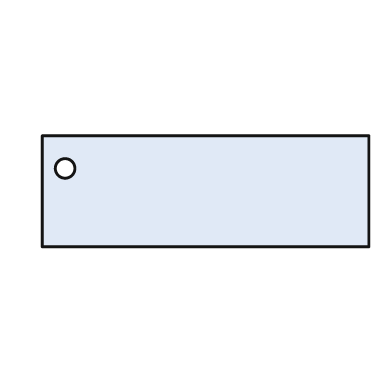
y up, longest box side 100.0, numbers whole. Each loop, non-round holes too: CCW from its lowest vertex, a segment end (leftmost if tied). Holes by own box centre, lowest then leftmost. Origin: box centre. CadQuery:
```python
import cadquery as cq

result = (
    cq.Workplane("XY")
    .moveTo(-50.0, -17.0)
    .lineTo(50.0, -17.0)
    .lineTo(50.0, 17.0)
    .lineTo(-50.0, 17.0)
    .close()
    .moveTo(-43.0, 7.0)
    .circle(3.0)
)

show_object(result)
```